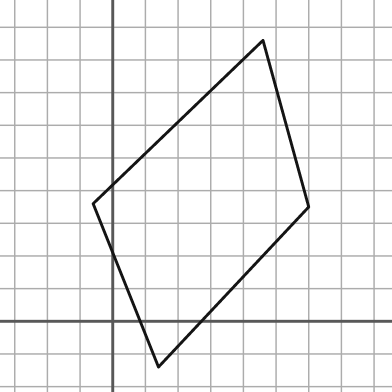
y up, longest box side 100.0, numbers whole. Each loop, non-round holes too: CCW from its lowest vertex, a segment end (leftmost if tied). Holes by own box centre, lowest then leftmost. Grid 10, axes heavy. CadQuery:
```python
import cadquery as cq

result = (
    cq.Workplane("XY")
    .moveTo(14.0, -14.0)
    .lineTo(60.0, 35.0)
    .lineTo(46.0, 86.0)
    .lineTo(-6.0, 36.0)
    .close()
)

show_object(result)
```